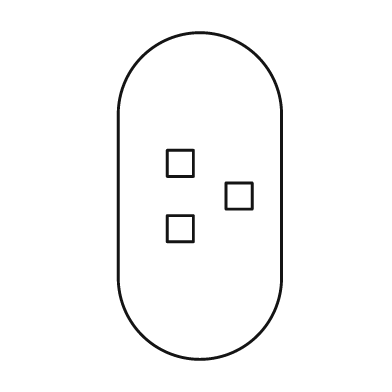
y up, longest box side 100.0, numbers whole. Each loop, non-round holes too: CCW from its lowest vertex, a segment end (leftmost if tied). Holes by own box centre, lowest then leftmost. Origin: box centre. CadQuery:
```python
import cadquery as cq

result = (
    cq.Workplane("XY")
    .moveTo(-25.0, -25.0)
    .threePointArc((0.0, -50.0), (25.0, -25.0))
    .lineTo(25.0, 25.0)
    .threePointArc((0.0, 50.0), (-25.0, 25.0))
    .close()
    .moveTo(-10.0, -14.0)
    .lineTo(-2.0, -14.0)
    .lineTo(-2.0, -6.0)
    .lineTo(-10.0, -6.0)
    .close()
    .moveTo(8.0, -4.0)
    .lineTo(16.0, -4.0)
    .lineTo(16.0, 4.0)
    .lineTo(8.0, 4.0)
    .close()
    .moveTo(-10.0, 6.0)
    .lineTo(-2.0, 6.0)
    .lineTo(-2.0, 14.0)
    .lineTo(-10.0, 14.0)
    .close()
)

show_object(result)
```